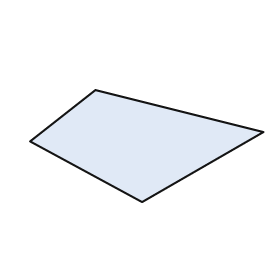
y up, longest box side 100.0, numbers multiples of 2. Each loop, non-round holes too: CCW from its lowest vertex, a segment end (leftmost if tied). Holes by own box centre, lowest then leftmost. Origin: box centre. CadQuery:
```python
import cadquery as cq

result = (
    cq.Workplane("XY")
    .moveTo(-2.0, -24.0)
    .lineTo(50.0, 6.0)
    .lineTo(-22.0, 24.0)
    .lineTo(-50.0, 2.0)
    .close()
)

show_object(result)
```